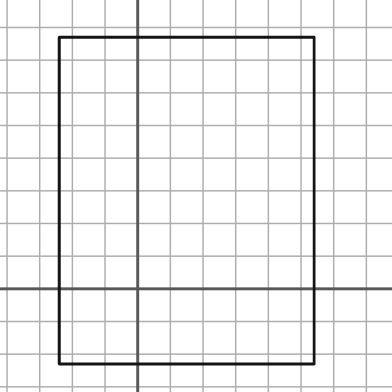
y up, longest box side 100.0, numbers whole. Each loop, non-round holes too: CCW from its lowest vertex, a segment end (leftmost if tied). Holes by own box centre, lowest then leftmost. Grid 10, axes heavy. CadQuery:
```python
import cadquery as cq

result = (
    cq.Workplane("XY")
    .moveTo(-24.0, -23.0)
    .lineTo(54.0, -23.0)
    .lineTo(54.0, 77.0)
    .lineTo(-24.0, 77.0)
    .close()
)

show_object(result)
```